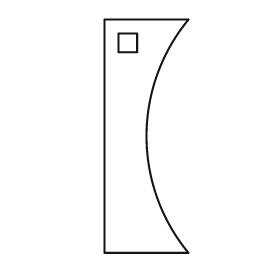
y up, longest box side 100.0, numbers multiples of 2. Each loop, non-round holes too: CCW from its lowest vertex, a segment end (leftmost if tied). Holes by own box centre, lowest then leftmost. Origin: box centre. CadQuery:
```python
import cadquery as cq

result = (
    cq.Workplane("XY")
    .moveTo(-18.0, -50.0)
    .lineTo(18.0, -50.0)
    .threePointArc((0.0, 0.0), (18.0, 50.0))
    .lineTo(-18.0, 50.0)
    .close()
    .moveTo(-12.0, 36.0)
    .lineTo(-4.0, 36.0)
    .lineTo(-4.0, 44.0)
    .lineTo(-12.0, 44.0)
    .close()
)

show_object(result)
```